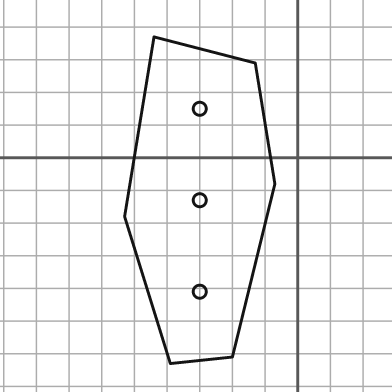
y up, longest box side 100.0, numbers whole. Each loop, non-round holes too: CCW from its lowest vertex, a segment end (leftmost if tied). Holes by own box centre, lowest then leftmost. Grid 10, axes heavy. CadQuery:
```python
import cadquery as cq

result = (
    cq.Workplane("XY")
    .moveTo(-39.0, -63.0)
    .lineTo(-20.0, -61.0)
    .lineTo(-7.0, -8.0)
    .lineTo(-13.0, 29.0)
    .lineTo(-44.0, 37.0)
    .lineTo(-53.0, -18.0)
    .close()
    .moveTo(-30.0, -41.0)
    .circle(2.0)
    .moveTo(-30.0, -13.0)
    .circle(2.0)
    .moveTo(-30.0, 15.0)
    .circle(2.0)
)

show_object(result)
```